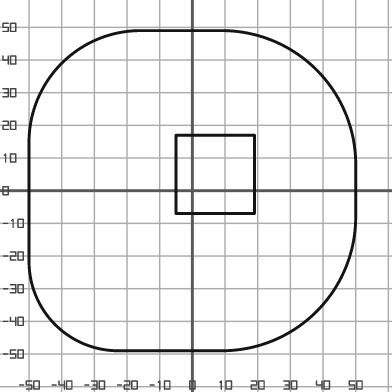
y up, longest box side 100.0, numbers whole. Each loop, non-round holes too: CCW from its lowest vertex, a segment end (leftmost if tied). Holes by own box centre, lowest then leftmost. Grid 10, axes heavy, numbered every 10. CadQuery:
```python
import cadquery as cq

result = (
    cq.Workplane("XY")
    .moveTo(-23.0, -49.0)
    .lineTo(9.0, -49.0)
    .threePointArc((38.0, -37.0), (50.0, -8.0))
    .lineTo(50.0, 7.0)
    .threePointArc((38.0, 37.0), (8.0, 49.0))
    .lineTo(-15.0, 49.0)
    .threePointArc((-40.0, 39.0), (-50.0, 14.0))
    .lineTo(-50.0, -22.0)
    .threePointArc((-42.0, -41.0), (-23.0, -49.0))
    .close()
    .moveTo(-5.0, -7.0)
    .lineTo(19.0, -7.0)
    .lineTo(19.0, 17.0)
    .lineTo(-5.0, 17.0)
    .close()
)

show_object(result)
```